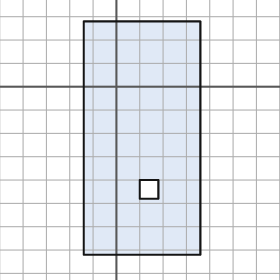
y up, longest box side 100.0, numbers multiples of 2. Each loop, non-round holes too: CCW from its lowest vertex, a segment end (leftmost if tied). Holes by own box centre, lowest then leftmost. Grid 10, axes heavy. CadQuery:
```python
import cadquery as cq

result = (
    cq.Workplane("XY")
    .moveTo(-14.0, -72.0)
    .lineTo(36.0, -72.0)
    .lineTo(36.0, 28.0)
    .lineTo(-14.0, 28.0)
    .close()
    .moveTo(10.0, -48.0)
    .lineTo(18.0, -48.0)
    .lineTo(18.0, -40.0)
    .lineTo(10.0, -40.0)
    .close()
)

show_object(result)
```